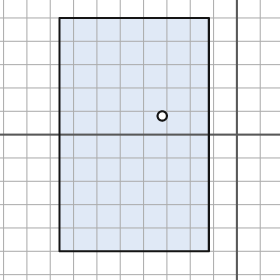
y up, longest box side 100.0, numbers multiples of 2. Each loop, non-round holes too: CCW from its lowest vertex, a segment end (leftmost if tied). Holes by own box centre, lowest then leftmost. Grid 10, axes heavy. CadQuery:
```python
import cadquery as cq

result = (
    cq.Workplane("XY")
    .moveTo(-76.0, -50.0)
    .lineTo(-12.0, -50.0)
    .lineTo(-12.0, 50.0)
    .lineTo(-76.0, 50.0)
    .close()
    .moveTo(-32.0, 8.0)
    .circle(2.0)
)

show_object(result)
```